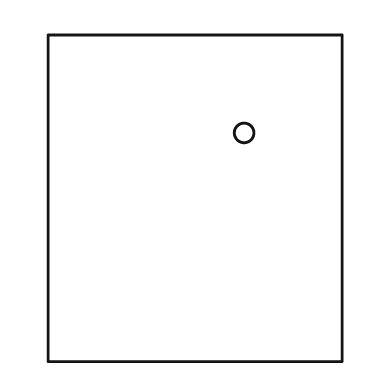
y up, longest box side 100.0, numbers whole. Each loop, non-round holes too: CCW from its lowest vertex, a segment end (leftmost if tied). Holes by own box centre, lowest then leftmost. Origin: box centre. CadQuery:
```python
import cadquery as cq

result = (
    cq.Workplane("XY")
    .moveTo(-45.0, -50.0)
    .lineTo(45.0, -50.0)
    .lineTo(45.0, 50.0)
    .lineTo(-45.0, 50.0)
    .close()
    .moveTo(15.0, 20.0)
    .circle(3.0)
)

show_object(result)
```